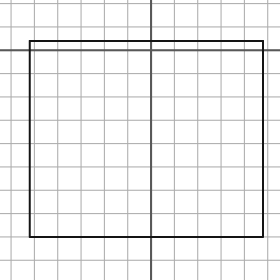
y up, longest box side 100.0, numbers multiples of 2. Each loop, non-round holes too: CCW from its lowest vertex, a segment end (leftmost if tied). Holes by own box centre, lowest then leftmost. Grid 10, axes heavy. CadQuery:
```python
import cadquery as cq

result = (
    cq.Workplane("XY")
    .moveTo(-52.0, -80.0)
    .lineTo(48.0, -80.0)
    .lineTo(48.0, 4.0)
    .lineTo(-52.0, 4.0)
    .close()
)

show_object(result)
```